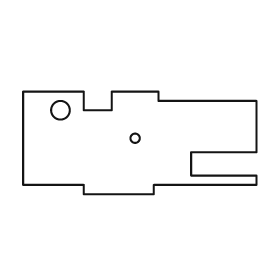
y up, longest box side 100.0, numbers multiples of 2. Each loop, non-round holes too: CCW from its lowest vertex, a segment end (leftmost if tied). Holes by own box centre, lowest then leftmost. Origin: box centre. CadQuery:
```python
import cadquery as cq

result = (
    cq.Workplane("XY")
    .moveTo(-24.0, -22.0)
    .lineTo(6.0, -22.0)
    .lineTo(6.0, -18.0)
    .lineTo(50.0, -18.0)
    .lineTo(50.0, -14.0)
    .lineTo(22.0, -14.0)
    .lineTo(22.0, -4.0)
    .lineTo(50.0, -4.0)
    .lineTo(50.0, 18.0)
    .lineTo(8.0, 18.0)
    .lineTo(8.0, 22.0)
    .lineTo(-12.0, 22.0)
    .lineTo(-12.0, 14.0)
    .lineTo(-24.0, 14.0)
    .lineTo(-24.0, 22.0)
    .lineTo(-50.0, 22.0)
    .lineTo(-50.0, -18.0)
    .lineTo(-24.0, -18.0)
    .close()
    .moveTo(-2.0, 2.0)
    .circle(2.0)
    .moveTo(-34.0, 14.0)
    .circle(4.0)
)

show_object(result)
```